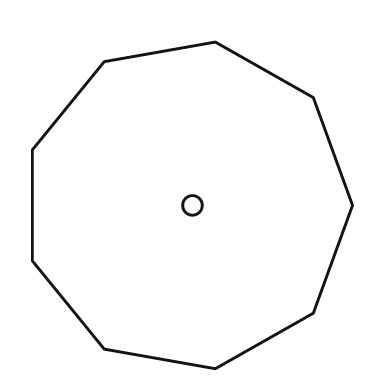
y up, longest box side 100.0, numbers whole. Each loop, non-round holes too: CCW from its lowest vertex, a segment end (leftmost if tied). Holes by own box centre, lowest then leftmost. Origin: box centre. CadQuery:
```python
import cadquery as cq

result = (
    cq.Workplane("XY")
    .moveTo(7.0, -50.0)
    .lineTo(37.0, -33.0)
    .lineTo(49.0, 0.0)
    .lineTo(37.0, 33.0)
    .lineTo(7.0, 50.0)
    .lineTo(-27.0, 44.0)
    .lineTo(-49.0, 17.0)
    .lineTo(-49.0, -17.0)
    .lineTo(-27.0, -44.0)
    .close()
    .moveTo(0.0, 0.0)
    .circle(3.0)
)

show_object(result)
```